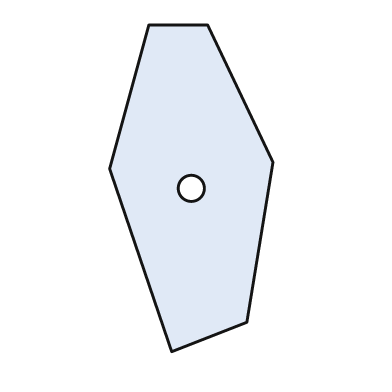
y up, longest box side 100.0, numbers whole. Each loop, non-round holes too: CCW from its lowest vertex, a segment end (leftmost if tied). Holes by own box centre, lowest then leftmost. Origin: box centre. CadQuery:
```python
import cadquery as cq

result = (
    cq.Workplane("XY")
    .moveTo(-6.0, -50.0)
    .lineTo(17.0, -41.0)
    .lineTo(25.0, 8.0)
    .lineTo(5.0, 50.0)
    .lineTo(-13.0, 50.0)
    .lineTo(-25.0, 6.0)
    .close()
    .moveTo(0.0, 0.0)
    .circle(4.0)
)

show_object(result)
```